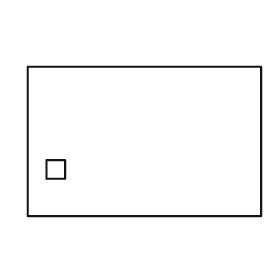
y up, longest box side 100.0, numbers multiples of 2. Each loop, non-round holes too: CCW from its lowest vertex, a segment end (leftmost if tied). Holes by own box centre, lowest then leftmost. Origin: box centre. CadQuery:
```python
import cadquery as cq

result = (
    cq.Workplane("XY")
    .moveTo(-50.0, -32.0)
    .lineTo(50.0, -32.0)
    .lineTo(50.0, 32.0)
    .lineTo(-50.0, 32.0)
    .close()
    .moveTo(-42.0, -16.0)
    .lineTo(-34.0, -16.0)
    .lineTo(-34.0, -8.0)
    .lineTo(-42.0, -8.0)
    .close()
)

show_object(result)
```